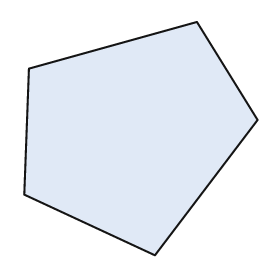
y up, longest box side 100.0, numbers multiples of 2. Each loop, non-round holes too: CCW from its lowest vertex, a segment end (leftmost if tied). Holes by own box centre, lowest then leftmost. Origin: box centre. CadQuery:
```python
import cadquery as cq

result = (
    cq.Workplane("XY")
    .moveTo(6.0, -50.0)
    .lineTo(50.0, 8.0)
    .lineTo(24.0, 50.0)
    .lineTo(-48.0, 30.0)
    .lineTo(-50.0, -24.0)
    .close()
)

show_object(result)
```